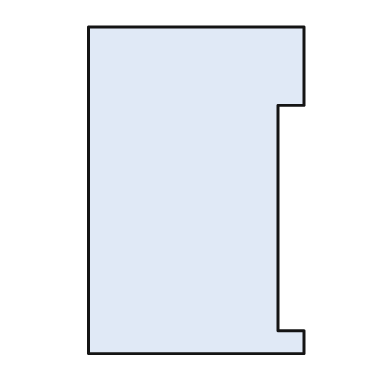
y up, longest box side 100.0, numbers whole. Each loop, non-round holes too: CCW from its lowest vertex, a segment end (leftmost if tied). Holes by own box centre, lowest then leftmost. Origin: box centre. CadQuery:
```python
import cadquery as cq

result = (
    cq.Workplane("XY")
    .moveTo(-33.0, -50.0)
    .lineTo(33.0, -50.0)
    .lineTo(33.0, -43.0)
    .lineTo(25.0, -43.0)
    .lineTo(25.0, 26.0)
    .lineTo(33.0, 26.0)
    .lineTo(33.0, 50.0)
    .lineTo(-33.0, 50.0)
    .close()
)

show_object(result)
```